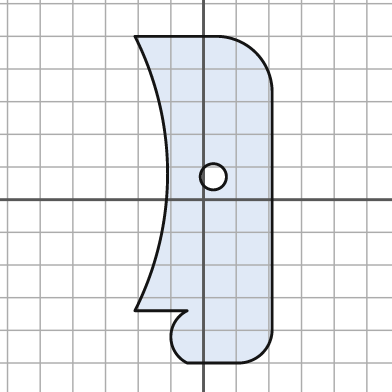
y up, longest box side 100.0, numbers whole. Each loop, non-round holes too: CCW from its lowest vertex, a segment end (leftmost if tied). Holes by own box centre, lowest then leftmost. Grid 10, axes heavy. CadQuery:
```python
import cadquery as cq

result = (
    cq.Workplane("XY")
    .moveTo(-5.0, -50.0)
    .lineTo(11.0, -50.0)
    .threePointArc((18.0, -47.0), (21.0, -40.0))
    .lineTo(21.0, 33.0)
    .threePointArc((16.0, 45.0), (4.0, 50.0))
    .lineTo(-21.0, 50.0)
    .threePointArc((-11.0, 8.0), (-21.0, -34.0))
    .lineTo(-5.0, -34.0)
    .threePointArc((-10.0, -42.0), (-5.0, -50.0))
    .close()
    .moveTo(3.0, 7.0)
    .circle(4.0)
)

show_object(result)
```